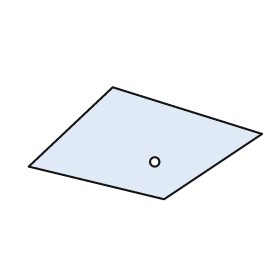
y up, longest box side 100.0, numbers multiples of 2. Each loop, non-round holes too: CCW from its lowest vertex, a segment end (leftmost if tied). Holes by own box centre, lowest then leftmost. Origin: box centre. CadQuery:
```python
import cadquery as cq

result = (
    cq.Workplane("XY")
    .moveTo(8.0, -24.0)
    .lineTo(50.0, 4.0)
    .lineTo(-14.0, 24.0)
    .lineTo(-50.0, -10.0)
    .close()
    .moveTo(4.0, -8.0)
    .circle(2.0)
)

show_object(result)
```